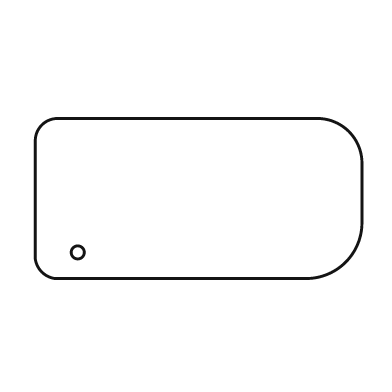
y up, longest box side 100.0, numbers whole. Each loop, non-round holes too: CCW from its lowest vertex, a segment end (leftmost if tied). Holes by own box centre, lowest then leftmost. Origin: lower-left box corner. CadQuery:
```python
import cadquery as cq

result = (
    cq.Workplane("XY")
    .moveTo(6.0, 0.0)
    .lineTo(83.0, 0.0)
    .threePointArc((95.0, 5.0), (100.0, 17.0))
    .lineTo(100.0, 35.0)
    .threePointArc((96.0, 45.0), (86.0, 49.0))
    .lineTo(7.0, 49.0)
    .threePointArc((2.0, 47.0), (0.0, 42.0))
    .lineTo(0.0, 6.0)
    .threePointArc((2.0, 2.0), (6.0, 0.0))
    .close()
    .moveTo(13.0, 8.0)
    .circle(2.0)
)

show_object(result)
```